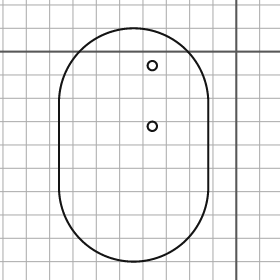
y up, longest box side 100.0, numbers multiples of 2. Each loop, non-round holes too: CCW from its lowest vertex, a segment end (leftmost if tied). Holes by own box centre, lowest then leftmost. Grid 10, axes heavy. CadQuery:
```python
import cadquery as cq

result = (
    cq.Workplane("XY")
    .moveTo(-76.0, -58.0)
    .threePointArc((-44.0, -90.0), (-12.0, -58.0))
    .lineTo(-12.0, -22.0)
    .threePointArc((-44.0, 10.0), (-76.0, -22.0))
    .close()
    .moveTo(-36.0, -32.0)
    .circle(2.0)
    .moveTo(-36.0, -6.0)
    .circle(2.0)
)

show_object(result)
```